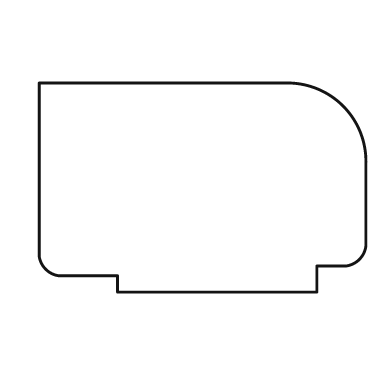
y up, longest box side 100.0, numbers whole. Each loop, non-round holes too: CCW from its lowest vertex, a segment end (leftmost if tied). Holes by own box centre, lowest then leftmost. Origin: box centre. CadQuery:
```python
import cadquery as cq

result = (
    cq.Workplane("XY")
    .moveTo(-26.0, -32.0)
    .lineTo(35.0, -32.0)
    .lineTo(35.0, -24.0)
    .lineTo(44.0, -24.0)
    .threePointArc((48.0, -22.0), (50.0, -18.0))
    .lineTo(50.0, 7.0)
    .threePointArc((43.0, 25.0), (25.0, 32.0))
    .lineTo(-50.0, 32.0)
    .lineTo(-50.0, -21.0)
    .threePointArc((-48.0, -25.0), (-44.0, -27.0))
    .lineTo(-26.0, -27.0)
    .close()
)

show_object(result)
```